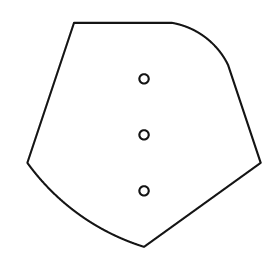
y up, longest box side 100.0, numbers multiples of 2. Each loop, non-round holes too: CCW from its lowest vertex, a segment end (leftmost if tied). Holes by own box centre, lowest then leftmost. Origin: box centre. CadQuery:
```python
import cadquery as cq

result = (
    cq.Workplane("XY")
    .moveTo(0.0, -48.0)
    .lineTo(50.0, -12.0)
    .lineTo(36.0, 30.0)
    .threePointArc((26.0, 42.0), (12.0, 48.0))
    .lineTo(-30.0, 48.0)
    .lineTo(-50.0, -12.0)
    .threePointArc((-28.0, -34.0), (0.0, -48.0))
    .close()
    .moveTo(0.0, -24.0)
    .circle(2.0)
    .moveTo(0.0, 0.0)
    .circle(2.0)
    .moveTo(0.0, 24.0)
    .circle(2.0)
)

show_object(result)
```